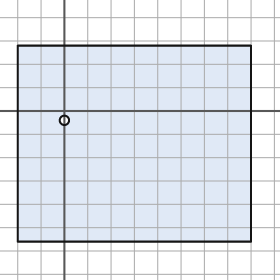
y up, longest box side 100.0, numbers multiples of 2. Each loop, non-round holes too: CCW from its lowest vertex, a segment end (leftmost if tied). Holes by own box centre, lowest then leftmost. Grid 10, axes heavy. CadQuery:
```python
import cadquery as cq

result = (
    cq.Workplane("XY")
    .moveTo(-20.0, -56.0)
    .lineTo(80.0, -56.0)
    .lineTo(80.0, 28.0)
    .lineTo(-20.0, 28.0)
    .close()
    .moveTo(0.0, -4.0)
    .circle(2.0)
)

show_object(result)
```